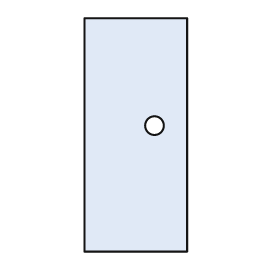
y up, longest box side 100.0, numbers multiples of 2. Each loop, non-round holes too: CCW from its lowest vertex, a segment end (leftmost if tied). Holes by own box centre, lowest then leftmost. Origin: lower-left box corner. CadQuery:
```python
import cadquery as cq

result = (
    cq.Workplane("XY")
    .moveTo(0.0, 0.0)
    .lineTo(44.0, 0.0)
    .lineTo(44.0, 100.0)
    .lineTo(0.0, 100.0)
    .close()
    .moveTo(30.0, 54.0)
    .circle(4.0)
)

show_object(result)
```